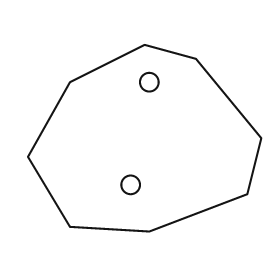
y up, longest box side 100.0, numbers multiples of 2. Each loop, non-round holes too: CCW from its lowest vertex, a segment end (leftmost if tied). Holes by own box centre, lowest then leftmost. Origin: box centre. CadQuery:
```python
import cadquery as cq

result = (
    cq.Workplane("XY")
    .moveTo(2.0, -40.0)
    .lineTo(44.0, -24.0)
    .lineTo(50.0, 0.0)
    .lineTo(22.0, 34.0)
    .lineTo(0.0, 40.0)
    .lineTo(-32.0, 24.0)
    .lineTo(-50.0, -8.0)
    .lineTo(-32.0, -38.0)
    .close()
    .moveTo(-6.0, -20.0)
    .circle(4.0)
    .moveTo(2.0, 24.0)
    .circle(4.0)
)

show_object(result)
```